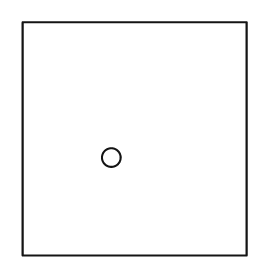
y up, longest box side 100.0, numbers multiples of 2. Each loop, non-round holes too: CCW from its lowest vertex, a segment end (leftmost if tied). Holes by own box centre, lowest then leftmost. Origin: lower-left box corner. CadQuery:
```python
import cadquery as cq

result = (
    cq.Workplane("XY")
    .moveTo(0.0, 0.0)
    .lineTo(96.0, 0.0)
    .lineTo(96.0, 100.0)
    .lineTo(0.0, 100.0)
    .close()
    .moveTo(38.0, 42.0)
    .circle(4.0)
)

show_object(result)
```